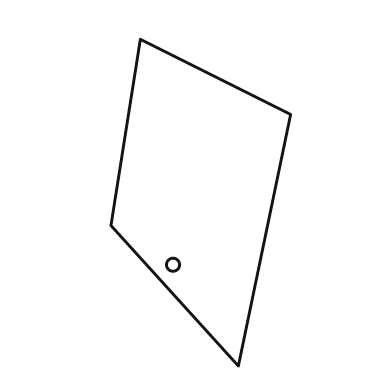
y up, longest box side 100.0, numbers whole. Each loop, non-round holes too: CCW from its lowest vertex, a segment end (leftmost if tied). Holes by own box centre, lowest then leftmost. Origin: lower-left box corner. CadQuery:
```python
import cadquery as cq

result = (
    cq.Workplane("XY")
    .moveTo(39.0, 0.0)
    .lineTo(55.0, 77.0)
    .lineTo(9.0, 100.0)
    .lineTo(0.0, 43.0)
    .close()
    .moveTo(19.0, 31.0)
    .circle(2.0)
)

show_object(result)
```